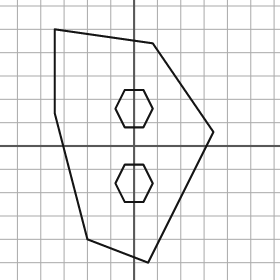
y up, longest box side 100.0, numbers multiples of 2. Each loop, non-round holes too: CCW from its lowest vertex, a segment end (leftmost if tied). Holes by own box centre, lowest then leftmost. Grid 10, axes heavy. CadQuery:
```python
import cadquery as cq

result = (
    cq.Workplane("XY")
    .moveTo(6.0, -50.0)
    .lineTo(34.0, 6.0)
    .lineTo(8.0, 44.0)
    .lineTo(-34.0, 50.0)
    .lineTo(-34.0, 14.0)
    .lineTo(-20.0, -40.0)
    .close()
    .moveTo(-4.0, -24.0)
    .lineTo(4.0, -24.0)
    .lineTo(8.0, -16.0)
    .lineTo(4.0, -8.0)
    .lineTo(-4.0, -8.0)
    .lineTo(-8.0, -16.0)
    .close()
    .moveTo(-4.0, 8.0)
    .lineTo(4.0, 8.0)
    .lineTo(8.0, 16.0)
    .lineTo(4.0, 24.0)
    .lineTo(-4.0, 24.0)
    .lineTo(-8.0, 16.0)
    .close()
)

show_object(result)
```